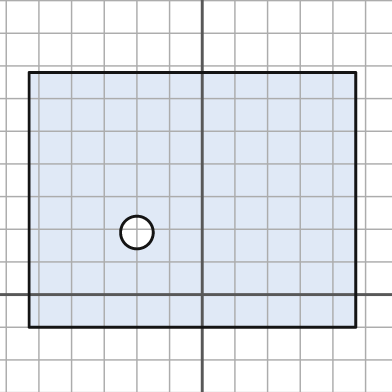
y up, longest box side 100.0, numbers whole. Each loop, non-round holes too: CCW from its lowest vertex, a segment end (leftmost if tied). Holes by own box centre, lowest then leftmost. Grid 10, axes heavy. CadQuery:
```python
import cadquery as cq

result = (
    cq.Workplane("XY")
    .moveTo(-53.0, -10.0)
    .lineTo(47.0, -10.0)
    .lineTo(47.0, 68.0)
    .lineTo(-53.0, 68.0)
    .close()
    .moveTo(-20.0, 19.0)
    .circle(5.0)
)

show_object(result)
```